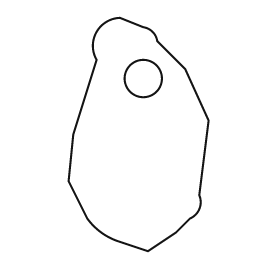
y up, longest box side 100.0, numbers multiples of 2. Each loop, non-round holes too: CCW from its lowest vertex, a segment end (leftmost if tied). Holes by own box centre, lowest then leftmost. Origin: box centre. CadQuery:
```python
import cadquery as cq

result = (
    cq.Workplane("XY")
    .moveTo(4.0, -50.0)
    .lineTo(16.0, -42.0)
    .lineTo(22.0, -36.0)
    .threePointArc((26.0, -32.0), (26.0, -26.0))
    .lineTo(30.0, 6.0)
    .lineTo(20.0, 28.0)
    .lineTo(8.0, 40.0)
    .threePointArc((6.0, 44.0), (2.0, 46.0))
    .lineTo(-8.0, 50.0)
    .threePointArc((-18.0, 44.0), (-18.0, 32.0))
    .lineTo(-28.0, 0.0)
    .lineTo(-30.0, -20.0)
    .lineTo(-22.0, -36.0)
    .threePointArc((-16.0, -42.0), (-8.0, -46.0))
    .close()
    .moveTo(2.0, 24.0)
    .circle(8.0)
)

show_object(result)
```